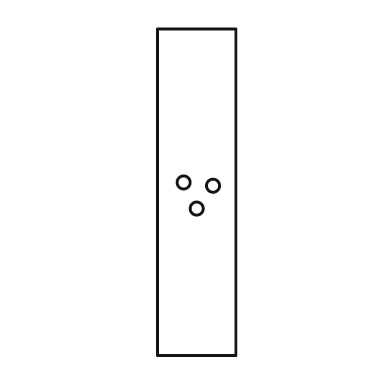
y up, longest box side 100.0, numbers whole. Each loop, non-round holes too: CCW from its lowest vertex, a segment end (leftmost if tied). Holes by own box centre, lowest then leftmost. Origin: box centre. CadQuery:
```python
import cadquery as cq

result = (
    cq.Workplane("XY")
    .moveTo(-12.0, -50.0)
    .lineTo(12.0, -50.0)
    .lineTo(12.0, 50.0)
    .lineTo(-12.0, 50.0)
    .close()
    .moveTo(0.0, -5.0)
    .circle(2.0)
    .moveTo(5.0, 2.0)
    .circle(2.0)
    .moveTo(-4.0, 3.0)
    .circle(2.0)
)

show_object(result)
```